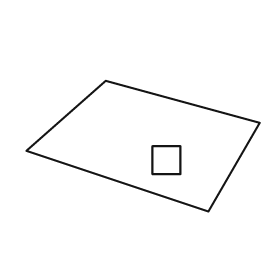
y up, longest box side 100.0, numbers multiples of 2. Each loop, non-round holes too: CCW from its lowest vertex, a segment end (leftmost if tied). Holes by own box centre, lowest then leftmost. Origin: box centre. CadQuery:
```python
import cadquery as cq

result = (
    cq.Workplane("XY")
    .moveTo(28.0, -28.0)
    .lineTo(50.0, 10.0)
    .lineTo(-16.0, 28.0)
    .lineTo(-50.0, -2.0)
    .close()
    .moveTo(4.0, -12.0)
    .lineTo(16.0, -12.0)
    .lineTo(16.0, 0.0)
    .lineTo(4.0, 0.0)
    .close()
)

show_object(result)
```